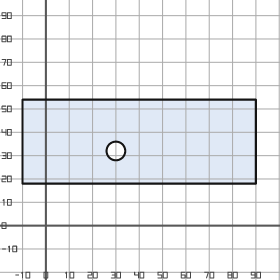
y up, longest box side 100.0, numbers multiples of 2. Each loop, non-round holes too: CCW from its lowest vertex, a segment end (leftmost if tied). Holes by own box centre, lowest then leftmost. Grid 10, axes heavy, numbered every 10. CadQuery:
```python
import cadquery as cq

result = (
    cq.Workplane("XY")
    .moveTo(-10.0, 18.0)
    .lineTo(90.0, 18.0)
    .lineTo(90.0, 54.0)
    .lineTo(-10.0, 54.0)
    .close()
    .moveTo(30.0, 32.0)
    .circle(4.0)
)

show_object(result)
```